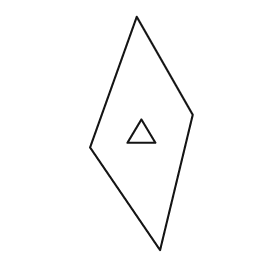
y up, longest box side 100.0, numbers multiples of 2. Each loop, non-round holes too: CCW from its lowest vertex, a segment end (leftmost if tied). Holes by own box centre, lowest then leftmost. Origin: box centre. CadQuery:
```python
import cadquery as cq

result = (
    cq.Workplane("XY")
    .moveTo(8.0, -50.0)
    .lineTo(22.0, 8.0)
    .lineTo(-2.0, 50.0)
    .lineTo(-22.0, -6.0)
    .close()
    .moveTo(-6.0, -4.0)
    .lineTo(6.0, -4.0)
    .lineTo(0.0, 6.0)
    .close()
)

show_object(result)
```